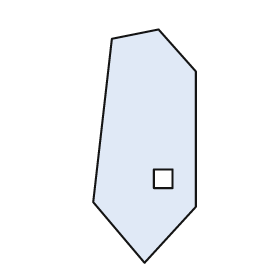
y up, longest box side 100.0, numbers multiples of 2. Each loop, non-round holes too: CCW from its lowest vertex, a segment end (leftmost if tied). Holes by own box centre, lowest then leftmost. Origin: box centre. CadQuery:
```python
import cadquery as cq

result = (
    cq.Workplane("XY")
    .moveTo(0.0, -50.0)
    .lineTo(22.0, -26.0)
    .lineTo(22.0, 32.0)
    .lineTo(6.0, 50.0)
    .lineTo(-14.0, 46.0)
    .lineTo(-22.0, -24.0)
    .close()
    .moveTo(4.0, -18.0)
    .lineTo(12.0, -18.0)
    .lineTo(12.0, -10.0)
    .lineTo(4.0, -10.0)
    .close()
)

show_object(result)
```